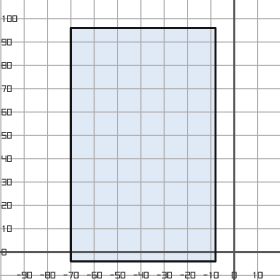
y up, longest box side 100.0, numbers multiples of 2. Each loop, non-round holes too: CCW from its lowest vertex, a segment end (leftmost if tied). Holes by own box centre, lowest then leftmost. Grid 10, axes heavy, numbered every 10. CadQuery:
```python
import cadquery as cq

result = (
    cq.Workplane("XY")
    .moveTo(-70.0, -4.0)
    .lineTo(-8.0, -4.0)
    .lineTo(-8.0, 96.0)
    .lineTo(-70.0, 96.0)
    .close()
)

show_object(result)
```